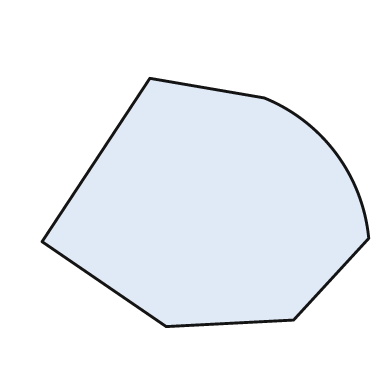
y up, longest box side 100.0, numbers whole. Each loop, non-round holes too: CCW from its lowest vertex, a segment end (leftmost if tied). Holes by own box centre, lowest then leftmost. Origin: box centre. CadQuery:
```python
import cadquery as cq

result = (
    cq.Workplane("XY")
    .moveTo(-12.0, -38.0)
    .lineTo(27.0, -36.0)
    .lineTo(50.0, -11.0)
    .threePointArc((40.0, 15.0), (18.0, 32.0))
    .lineTo(-17.0, 38.0)
    .lineTo(-50.0, -12.0)
    .close()
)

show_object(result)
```